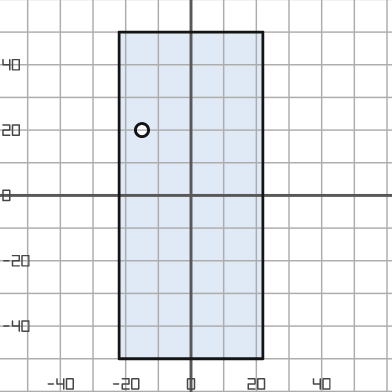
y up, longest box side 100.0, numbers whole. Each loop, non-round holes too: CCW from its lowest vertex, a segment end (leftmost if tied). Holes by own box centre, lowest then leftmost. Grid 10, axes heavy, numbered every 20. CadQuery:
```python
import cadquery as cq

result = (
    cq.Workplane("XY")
    .moveTo(-22.0, -50.0)
    .lineTo(22.0, -50.0)
    .lineTo(22.0, 50.0)
    .lineTo(-22.0, 50.0)
    .close()
    .moveTo(-15.0, 20.0)
    .circle(2.0)
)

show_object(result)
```